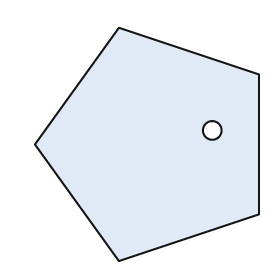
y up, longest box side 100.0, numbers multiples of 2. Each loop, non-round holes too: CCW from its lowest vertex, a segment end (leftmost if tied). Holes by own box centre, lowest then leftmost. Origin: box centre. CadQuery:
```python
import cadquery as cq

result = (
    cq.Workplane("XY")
    .moveTo(-12.0, -50.0)
    .lineTo(48.0, -30.0)
    .lineTo(48.0, 30.0)
    .lineTo(-12.0, 50.0)
    .lineTo(-48.0, 0.0)
    .close()
    .moveTo(28.0, 6.0)
    .circle(4.0)
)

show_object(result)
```